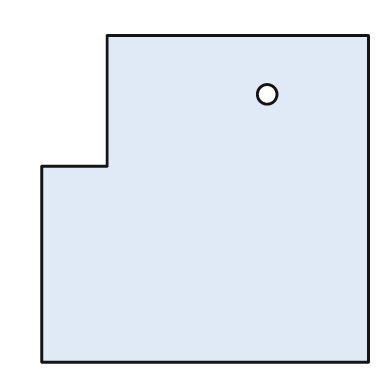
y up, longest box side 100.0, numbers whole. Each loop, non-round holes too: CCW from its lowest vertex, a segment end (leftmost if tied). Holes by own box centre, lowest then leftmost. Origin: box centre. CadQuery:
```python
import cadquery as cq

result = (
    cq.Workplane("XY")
    .moveTo(-50.0, -50.0)
    .lineTo(50.0, -50.0)
    .lineTo(50.0, 50.0)
    .lineTo(-30.0, 50.0)
    .lineTo(-30.0, 10.0)
    .lineTo(-50.0, 10.0)
    .close()
    .moveTo(19.0, 32.0)
    .circle(3.0)
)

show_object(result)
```